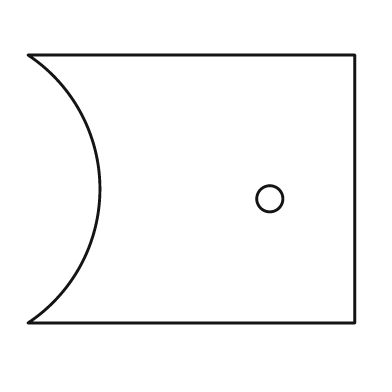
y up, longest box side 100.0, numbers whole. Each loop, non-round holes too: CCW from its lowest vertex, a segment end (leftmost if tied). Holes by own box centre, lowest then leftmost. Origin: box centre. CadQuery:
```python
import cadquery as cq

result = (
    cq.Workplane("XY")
    .moveTo(-50.0, -41.0)
    .lineTo(50.0, -41.0)
    .lineTo(50.0, 41.0)
    .lineTo(-50.0, 41.0)
    .threePointArc((-28.0, 0.0), (-50.0, -41.0))
    .close()
    .moveTo(24.0, -3.0)
    .circle(4.0)
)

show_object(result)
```